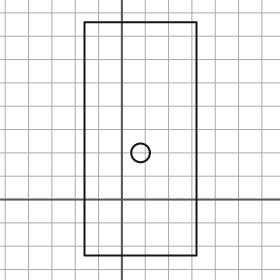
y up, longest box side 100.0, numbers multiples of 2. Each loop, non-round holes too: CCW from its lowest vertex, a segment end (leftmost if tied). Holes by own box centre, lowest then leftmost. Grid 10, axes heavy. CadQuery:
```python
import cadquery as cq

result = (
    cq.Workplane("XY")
    .moveTo(-16.0, -24.0)
    .lineTo(32.0, -24.0)
    .lineTo(32.0, 76.0)
    .lineTo(-16.0, 76.0)
    .close()
    .moveTo(8.0, 20.0)
    .circle(4.0)
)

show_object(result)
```